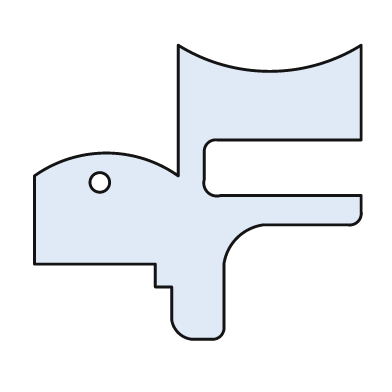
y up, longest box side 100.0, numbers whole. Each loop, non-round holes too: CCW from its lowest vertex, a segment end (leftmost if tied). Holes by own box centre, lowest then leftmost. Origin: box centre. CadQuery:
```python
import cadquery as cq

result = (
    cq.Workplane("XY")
    .moveTo(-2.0, -45.0)
    .lineTo(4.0, -45.0)
    .threePointArc((7.0, -44.0), (8.0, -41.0))
    .lineTo(8.0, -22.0)
    .threePointArc((12.0, -14.0), (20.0, -10.0))
    .lineTo(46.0, -10.0)
    .threePointArc((49.0, -9.0), (50.0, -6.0))
    .lineTo(50.0, -1.0)
    .lineTo(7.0, -1.0)
    .threePointArc((3.0, 0.0), (2.0, 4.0))
    .lineTo(2.0, 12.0)
    .threePointArc((3.0, 15.0), (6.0, 16.0))
    .lineTo(50.0, 16.0)
    .lineTo(50.0, 45.0)
    .threePointArc((22.0, 37.0), (-6.0, 45.0))
    .lineTo(-6.0, 5.0)
    .threePointArc((-28.0, 12.0), (-50.0, 5.0))
    .lineTo(-50.0, -22.0)
    .lineTo(-13.0, -22.0)
    .lineTo(-13.0, -29.0)
    .lineTo(-8.0, -29.0)
    .lineTo(-8.0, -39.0)
    .threePointArc((-6.0, -43.0), (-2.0, -45.0))
    .close()
    .moveTo(-30.0, 3.0)
    .circle(3.0)
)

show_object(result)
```